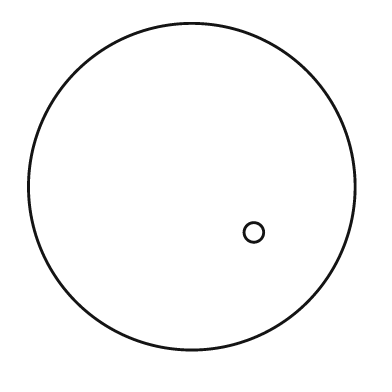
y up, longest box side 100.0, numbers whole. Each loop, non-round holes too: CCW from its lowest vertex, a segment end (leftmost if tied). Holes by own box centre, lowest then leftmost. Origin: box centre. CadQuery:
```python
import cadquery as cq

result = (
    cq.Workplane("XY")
    .moveTo(0.0, 0.0)
    .circle(50.0)
    .moveTo(19.0, -14.0)
    .circle(3.0)
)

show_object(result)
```